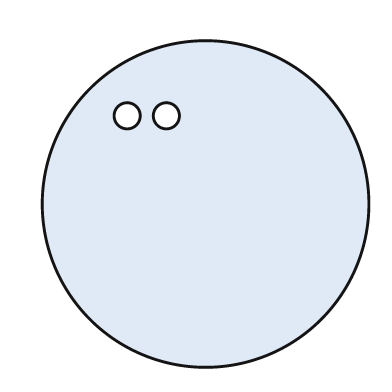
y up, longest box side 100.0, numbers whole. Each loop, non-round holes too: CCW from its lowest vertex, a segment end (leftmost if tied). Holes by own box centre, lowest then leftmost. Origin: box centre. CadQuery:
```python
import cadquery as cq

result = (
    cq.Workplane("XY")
    .moveTo(0.0, 0.0)
    .circle(50.0)
    .moveTo(-24.0, 27.0)
    .circle(4.0)
    .moveTo(-12.0, 27.0)
    .circle(4.0)
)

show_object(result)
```